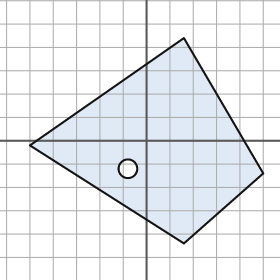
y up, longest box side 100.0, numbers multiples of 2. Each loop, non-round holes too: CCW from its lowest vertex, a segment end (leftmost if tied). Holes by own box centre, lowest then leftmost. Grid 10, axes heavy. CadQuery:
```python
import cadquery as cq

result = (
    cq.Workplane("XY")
    .moveTo(16.0, -44.0)
    .lineTo(50.0, -14.0)
    .lineTo(16.0, 44.0)
    .lineTo(-50.0, -2.0)
    .close()
    .moveTo(-8.0, -12.0)
    .circle(4.0)
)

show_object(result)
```